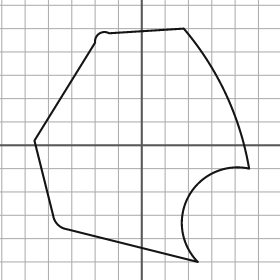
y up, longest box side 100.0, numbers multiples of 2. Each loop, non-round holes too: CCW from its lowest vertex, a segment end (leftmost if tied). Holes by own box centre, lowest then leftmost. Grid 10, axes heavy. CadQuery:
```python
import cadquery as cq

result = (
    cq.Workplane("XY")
    .moveTo(24.0, -50.0)
    .threePointArc((20.0, -22.0), (46.0, -10.0))
    .threePointArc((36.0, 22.0), (18.0, 50.0))
    .lineTo(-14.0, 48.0)
    .threePointArc((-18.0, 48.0), (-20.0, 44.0))
    .lineTo(-46.0, 2.0)
    .lineTo(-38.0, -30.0)
    .threePointArc((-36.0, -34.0), (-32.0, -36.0))
    .close()
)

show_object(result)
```